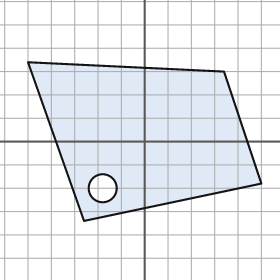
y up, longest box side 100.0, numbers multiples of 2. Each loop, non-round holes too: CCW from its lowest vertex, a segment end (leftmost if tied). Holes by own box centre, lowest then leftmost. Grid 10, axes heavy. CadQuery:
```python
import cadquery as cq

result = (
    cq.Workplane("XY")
    .moveTo(-26.0, -34.0)
    .lineTo(50.0, -18.0)
    .lineTo(34.0, 30.0)
    .lineTo(-50.0, 34.0)
    .close()
    .moveTo(-18.0, -20.0)
    .circle(6.0)
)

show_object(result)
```